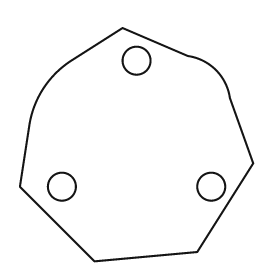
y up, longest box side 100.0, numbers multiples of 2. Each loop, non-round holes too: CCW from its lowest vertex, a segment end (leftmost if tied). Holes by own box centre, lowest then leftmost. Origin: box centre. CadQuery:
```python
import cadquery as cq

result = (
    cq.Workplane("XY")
    .moveTo(-18.0, -50.0)
    .lineTo(26.0, -46.0)
    .lineTo(50.0, -8.0)
    .lineTo(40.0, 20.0)
    .threePointArc((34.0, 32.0), (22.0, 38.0))
    .lineTo(-6.0, 50.0)
    .lineTo(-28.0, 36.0)
    .threePointArc((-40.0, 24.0), (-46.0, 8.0))
    .lineTo(-50.0, -18.0)
    .close()
    .moveTo(-32.0, -18.0)
    .circle(6.0)
    .moveTo(32.0, -18.0)
    .circle(6.0)
    .moveTo(0.0, 36.0)
    .circle(6.0)
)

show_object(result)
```